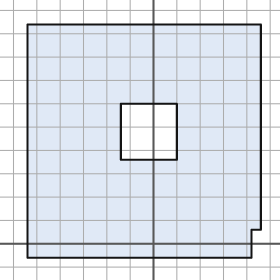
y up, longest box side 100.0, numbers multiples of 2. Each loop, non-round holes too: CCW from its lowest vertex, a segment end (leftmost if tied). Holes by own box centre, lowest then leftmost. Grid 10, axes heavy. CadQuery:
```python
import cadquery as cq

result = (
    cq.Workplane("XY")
    .moveTo(-54.0, -6.0)
    .lineTo(42.0, -6.0)
    .lineTo(42.0, 6.0)
    .lineTo(46.0, 6.0)
    .lineTo(46.0, 94.0)
    .lineTo(-54.0, 94.0)
    .close()
    .moveTo(-14.0, 36.0)
    .lineTo(10.0, 36.0)
    .lineTo(10.0, 60.0)
    .lineTo(-14.0, 60.0)
    .close()
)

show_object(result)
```